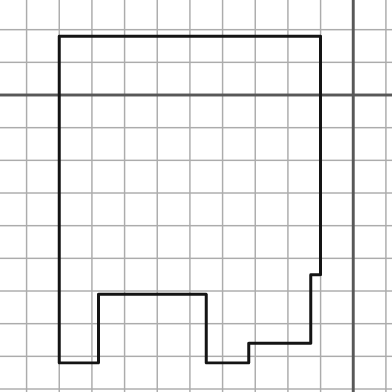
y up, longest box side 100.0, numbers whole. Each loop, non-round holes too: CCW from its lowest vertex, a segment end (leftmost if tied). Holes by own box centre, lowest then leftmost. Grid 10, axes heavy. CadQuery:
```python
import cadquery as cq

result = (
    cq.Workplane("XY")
    .moveTo(-90.0, -82.0)
    .lineTo(-78.0, -82.0)
    .lineTo(-78.0, -61.0)
    .lineTo(-45.0, -61.0)
    .lineTo(-45.0, -82.0)
    .lineTo(-32.0, -82.0)
    .lineTo(-32.0, -76.0)
    .lineTo(-13.0, -76.0)
    .lineTo(-13.0, -55.0)
    .lineTo(-10.0, -55.0)
    .lineTo(-10.0, 18.0)
    .lineTo(-90.0, 18.0)
    .close()
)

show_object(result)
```